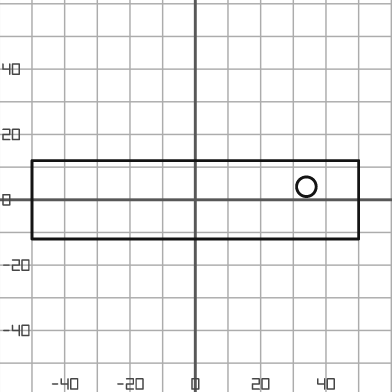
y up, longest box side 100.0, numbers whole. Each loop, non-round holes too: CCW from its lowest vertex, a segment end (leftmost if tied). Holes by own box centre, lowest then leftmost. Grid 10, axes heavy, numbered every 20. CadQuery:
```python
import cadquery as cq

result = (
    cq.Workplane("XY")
    .moveTo(-50.0, -12.0)
    .lineTo(50.0, -12.0)
    .lineTo(50.0, 12.0)
    .lineTo(-50.0, 12.0)
    .close()
    .moveTo(34.0, 4.0)
    .circle(3.0)
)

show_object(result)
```